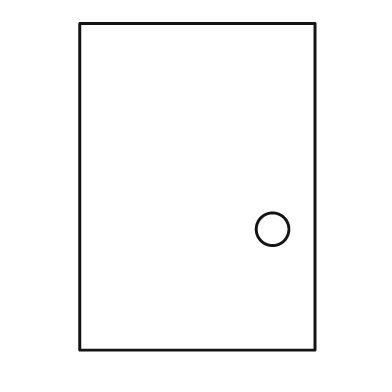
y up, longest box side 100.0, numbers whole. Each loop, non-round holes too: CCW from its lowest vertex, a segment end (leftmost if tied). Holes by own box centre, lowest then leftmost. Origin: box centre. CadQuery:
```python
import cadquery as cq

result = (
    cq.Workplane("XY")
    .moveTo(-36.0, -50.0)
    .lineTo(36.0, -50.0)
    .lineTo(36.0, 50.0)
    .lineTo(-36.0, 50.0)
    .close()
    .moveTo(23.0, -13.0)
    .circle(5.0)
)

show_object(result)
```